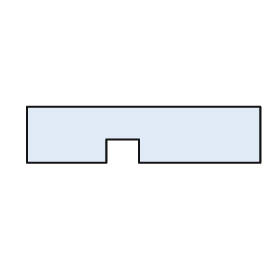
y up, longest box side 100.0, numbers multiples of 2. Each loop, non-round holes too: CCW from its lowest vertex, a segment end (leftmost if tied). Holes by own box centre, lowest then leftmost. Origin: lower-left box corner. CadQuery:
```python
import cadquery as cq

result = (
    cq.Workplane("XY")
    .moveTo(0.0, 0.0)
    .lineTo(34.0, 0.0)
    .lineTo(34.0, 10.0)
    .lineTo(48.0, 10.0)
    .lineTo(48.0, 0.0)
    .lineTo(100.0, 0.0)
    .lineTo(100.0, 24.0)
    .lineTo(0.0, 24.0)
    .close()
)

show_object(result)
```